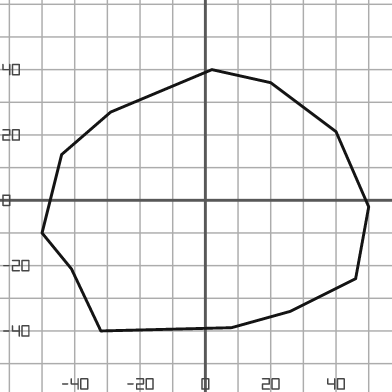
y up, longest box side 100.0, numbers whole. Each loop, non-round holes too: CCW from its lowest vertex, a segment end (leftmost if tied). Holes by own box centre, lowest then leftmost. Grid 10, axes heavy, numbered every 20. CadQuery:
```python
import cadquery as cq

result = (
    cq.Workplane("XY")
    .moveTo(-32.0, -40.0)
    .lineTo(8.0, -39.0)
    .lineTo(26.0, -34.0)
    .lineTo(46.0, -24.0)
    .lineTo(50.0, -2.0)
    .lineTo(40.0, 21.0)
    .lineTo(20.0, 36.0)
    .lineTo(2.0, 40.0)
    .lineTo(-29.0, 27.0)
    .lineTo(-44.0, 14.0)
    .lineTo(-50.0, -10.0)
    .lineTo(-41.0, -21.0)
    .close()
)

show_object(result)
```